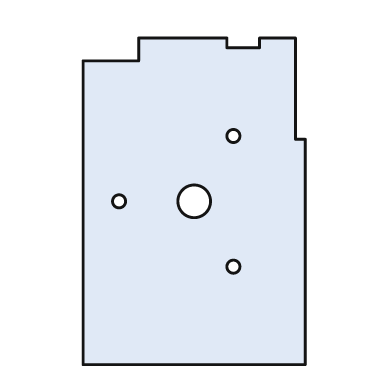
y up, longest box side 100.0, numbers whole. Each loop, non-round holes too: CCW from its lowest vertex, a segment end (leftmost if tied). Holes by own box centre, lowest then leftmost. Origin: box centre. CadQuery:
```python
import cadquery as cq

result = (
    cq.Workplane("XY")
    .moveTo(-34.0, -50.0)
    .lineTo(34.0, -50.0)
    .lineTo(34.0, 19.0)
    .lineTo(31.0, 19.0)
    .lineTo(31.0, 50.0)
    .lineTo(20.0, 50.0)
    .lineTo(20.0, 47.0)
    .lineTo(10.0, 47.0)
    .lineTo(10.0, 50.0)
    .lineTo(-17.0, 50.0)
    .lineTo(-17.0, 43.0)
    .lineTo(-34.0, 43.0)
    .close()
    .moveTo(12.0, -20.0)
    .circle(2.0)
    .moveTo(-23.0, 0.0)
    .circle(2.0)
    .moveTo(0.0, 0.0)
    .circle(5.0)
    .moveTo(12.0, 20.0)
    .circle(2.0)
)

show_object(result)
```